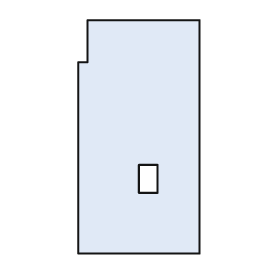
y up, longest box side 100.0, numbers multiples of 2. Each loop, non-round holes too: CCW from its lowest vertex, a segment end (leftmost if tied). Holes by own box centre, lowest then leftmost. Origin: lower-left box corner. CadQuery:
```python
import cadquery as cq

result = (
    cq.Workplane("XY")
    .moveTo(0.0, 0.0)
    .lineTo(52.0, 0.0)
    .lineTo(52.0, 100.0)
    .lineTo(4.0, 100.0)
    .lineTo(4.0, 82.0)
    .lineTo(0.0, 82.0)
    .close()
    .moveTo(26.0, 26.0)
    .lineTo(34.0, 26.0)
    .lineTo(34.0, 38.0)
    .lineTo(26.0, 38.0)
    .close()
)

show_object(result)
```